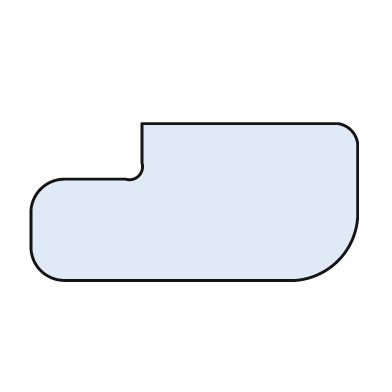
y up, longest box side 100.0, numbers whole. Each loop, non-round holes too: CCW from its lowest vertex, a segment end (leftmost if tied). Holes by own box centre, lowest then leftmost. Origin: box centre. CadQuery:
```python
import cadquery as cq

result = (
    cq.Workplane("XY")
    .moveTo(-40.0, -24.0)
    .lineTo(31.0, -24.0)
    .threePointArc((44.0, -18.0), (50.0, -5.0))
    .lineTo(50.0, 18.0)
    .threePointArc((48.0, 22.0), (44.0, 24.0))
    .lineTo(-16.0, 24.0)
    .lineTo(-16.0, 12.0)
    .threePointArc((-17.0, 8.0), (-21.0, 7.0))
    .lineTo(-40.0, 7.0)
    .threePointArc((-47.0, 4.0), (-50.0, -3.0))
    .lineTo(-50.0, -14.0)
    .threePointArc((-47.0, -21.0), (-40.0, -24.0))
    .close()
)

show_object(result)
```